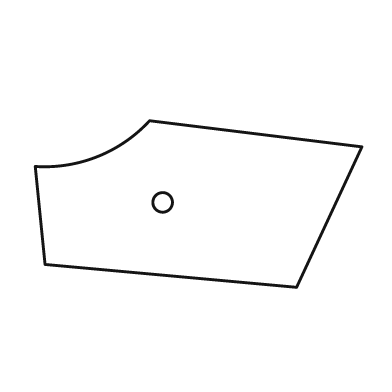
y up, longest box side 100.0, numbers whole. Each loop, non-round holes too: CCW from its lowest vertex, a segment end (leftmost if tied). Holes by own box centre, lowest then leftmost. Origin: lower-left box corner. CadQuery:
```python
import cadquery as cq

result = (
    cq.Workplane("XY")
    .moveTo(80.0, 0.0)
    .lineTo(100.0, 43.0)
    .lineTo(35.0, 51.0)
    .threePointArc((19.0, 40.0), (0.0, 37.0))
    .lineTo(3.0, 7.0)
    .close()
    .moveTo(39.0, 26.0)
    .circle(3.0)
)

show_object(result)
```